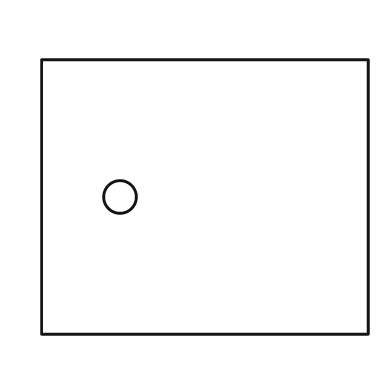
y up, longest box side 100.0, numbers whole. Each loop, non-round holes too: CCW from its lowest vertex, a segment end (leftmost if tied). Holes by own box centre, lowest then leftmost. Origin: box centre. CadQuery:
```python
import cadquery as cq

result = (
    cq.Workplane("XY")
    .moveTo(-50.0, -42.0)
    .lineTo(50.0, -42.0)
    .lineTo(50.0, 42.0)
    .lineTo(-50.0, 42.0)
    .close()
    .moveTo(-26.0, 0.0)
    .circle(5.0)
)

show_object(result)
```